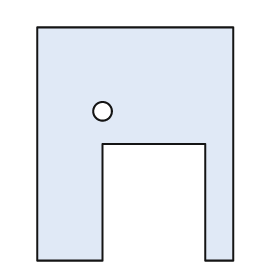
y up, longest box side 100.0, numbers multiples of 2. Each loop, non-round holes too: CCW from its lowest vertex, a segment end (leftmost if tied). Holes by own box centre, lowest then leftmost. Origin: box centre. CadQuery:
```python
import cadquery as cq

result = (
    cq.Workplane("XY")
    .moveTo(-42.0, -50.0)
    .lineTo(-14.0, -50.0)
    .lineTo(-14.0, 0.0)
    .lineTo(30.0, 0.0)
    .lineTo(30.0, -50.0)
    .lineTo(42.0, -50.0)
    .lineTo(42.0, 50.0)
    .lineTo(-42.0, 50.0)
    .close()
    .moveTo(-14.0, 14.0)
    .circle(4.0)
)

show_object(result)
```